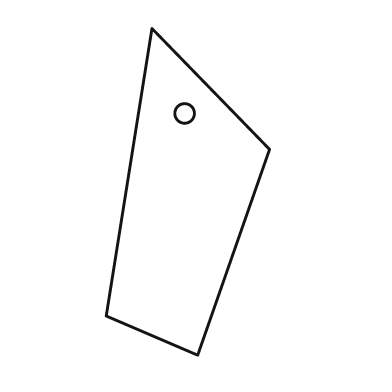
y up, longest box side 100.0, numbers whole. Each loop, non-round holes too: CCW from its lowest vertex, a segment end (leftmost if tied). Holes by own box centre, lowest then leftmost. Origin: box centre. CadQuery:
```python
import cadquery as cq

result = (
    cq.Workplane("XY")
    .moveTo(3.0, -50.0)
    .lineTo(25.0, 13.0)
    .lineTo(-11.0, 50.0)
    .lineTo(-25.0, -38.0)
    .close()
    .moveTo(-1.0, 24.0)
    .circle(3.0)
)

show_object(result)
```